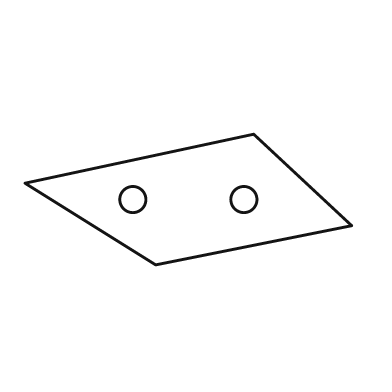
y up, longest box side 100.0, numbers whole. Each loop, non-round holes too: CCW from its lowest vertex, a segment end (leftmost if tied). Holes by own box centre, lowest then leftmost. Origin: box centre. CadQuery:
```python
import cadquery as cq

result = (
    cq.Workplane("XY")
    .moveTo(-10.0, -20.0)
    .lineTo(50.0, -8.0)
    .lineTo(20.0, 20.0)
    .lineTo(-50.0, 5.0)
    .close()
    .moveTo(-17.0, 0.0)
    .circle(4.0)
    .moveTo(17.0, 0.0)
    .circle(4.0)
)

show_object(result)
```